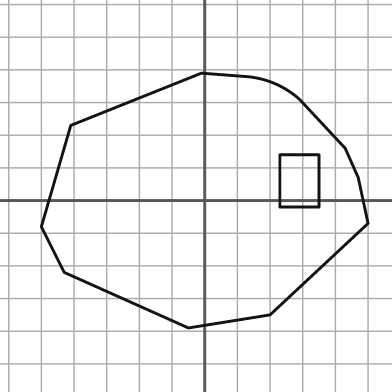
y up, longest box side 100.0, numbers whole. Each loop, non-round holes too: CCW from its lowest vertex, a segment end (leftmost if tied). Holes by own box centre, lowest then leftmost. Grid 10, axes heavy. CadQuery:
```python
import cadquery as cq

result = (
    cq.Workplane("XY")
    .moveTo(-5.0, -39.0)
    .lineTo(20.0, -35.0)
    .lineTo(50.0, -7.0)
    .lineTo(47.0, 7.0)
    .lineTo(43.0, 16.0)
    .lineTo(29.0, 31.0)
    .threePointArc((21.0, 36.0), (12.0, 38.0))
    .lineTo(-1.0, 39.0)
    .lineTo(-41.0, 23.0)
    .lineTo(-50.0, -8.0)
    .lineTo(-43.0, -22.0)
    .close()
    .moveTo(23.0, -2.0)
    .lineTo(35.0, -2.0)
    .lineTo(35.0, 14.0)
    .lineTo(23.0, 14.0)
    .close()
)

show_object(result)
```